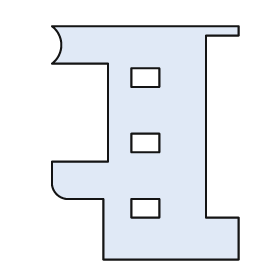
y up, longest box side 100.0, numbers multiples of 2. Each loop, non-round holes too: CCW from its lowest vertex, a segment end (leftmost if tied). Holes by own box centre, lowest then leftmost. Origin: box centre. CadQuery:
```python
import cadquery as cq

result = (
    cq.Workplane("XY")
    .moveTo(-18.0, -50.0)
    .lineTo(40.0, -50.0)
    .lineTo(40.0, -32.0)
    .lineTo(26.0, -32.0)
    .lineTo(26.0, 46.0)
    .lineTo(40.0, 46.0)
    .lineTo(40.0, 50.0)
    .lineTo(-40.0, 50.0)
    .threePointArc((-36.0, 42.0), (-40.0, 34.0))
    .lineTo(-16.0, 34.0)
    .lineTo(-16.0, -8.0)
    .lineTo(-40.0, -8.0)
    .lineTo(-40.0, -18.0)
    .threePointArc((-38.0, -22.0), (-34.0, -24.0))
    .lineTo(-18.0, -24.0)
    .close()
    .moveTo(-6.0, -32.0)
    .lineTo(6.0, -32.0)
    .lineTo(6.0, -24.0)
    .lineTo(-6.0, -24.0)
    .close()
    .moveTo(-6.0, -4.0)
    .lineTo(6.0, -4.0)
    .lineTo(6.0, 4.0)
    .lineTo(-6.0, 4.0)
    .close()
    .moveTo(-6.0, 24.0)
    .lineTo(6.0, 24.0)
    .lineTo(6.0, 32.0)
    .lineTo(-6.0, 32.0)
    .close()
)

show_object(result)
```